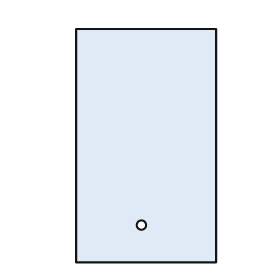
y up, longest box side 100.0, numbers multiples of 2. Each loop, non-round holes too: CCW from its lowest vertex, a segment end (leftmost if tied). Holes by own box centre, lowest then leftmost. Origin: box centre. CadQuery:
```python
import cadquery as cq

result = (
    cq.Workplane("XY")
    .moveTo(-30.0, -50.0)
    .lineTo(30.0, -50.0)
    .lineTo(30.0, 50.0)
    .lineTo(-30.0, 50.0)
    .close()
    .moveTo(-2.0, -34.0)
    .circle(2.0)
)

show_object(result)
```